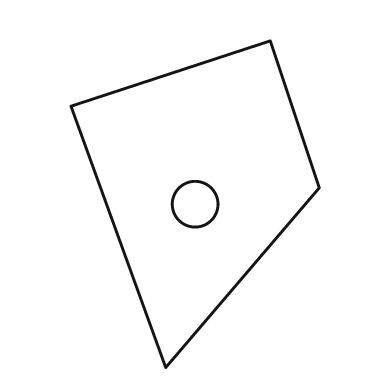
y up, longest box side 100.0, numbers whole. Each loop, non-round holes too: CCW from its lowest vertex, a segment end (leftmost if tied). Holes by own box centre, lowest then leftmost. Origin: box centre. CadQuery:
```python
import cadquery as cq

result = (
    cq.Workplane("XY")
    .moveTo(-9.0, -50.0)
    .lineTo(38.0, 5.0)
    .lineTo(23.0, 50.0)
    .lineTo(-38.0, 30.0)
    .close()
    .moveTo(0.0, 0.0)
    .circle(7.0)
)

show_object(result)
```